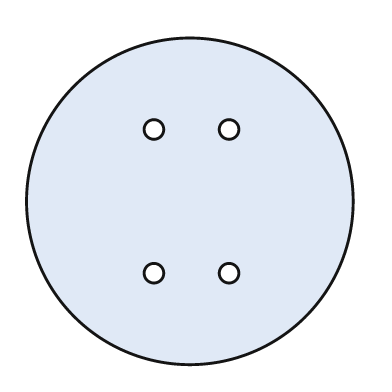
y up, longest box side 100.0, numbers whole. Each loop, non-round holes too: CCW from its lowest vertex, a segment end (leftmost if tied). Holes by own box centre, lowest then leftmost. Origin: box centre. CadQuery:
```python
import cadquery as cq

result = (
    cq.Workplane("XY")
    .moveTo(0.0, 0.0)
    .circle(50.0)
    .moveTo(-11.0, -22.0)
    .circle(3.0)
    .moveTo(12.0, -22.0)
    .circle(3.0)
    .moveTo(-11.0, 22.0)
    .circle(3.0)
    .moveTo(12.0, 22.0)
    .circle(3.0)
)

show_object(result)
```